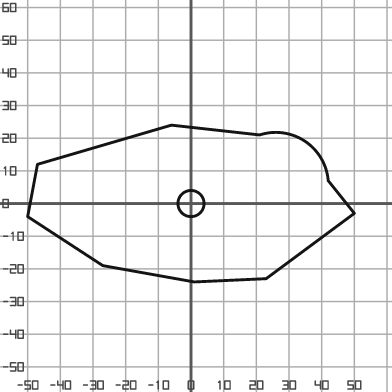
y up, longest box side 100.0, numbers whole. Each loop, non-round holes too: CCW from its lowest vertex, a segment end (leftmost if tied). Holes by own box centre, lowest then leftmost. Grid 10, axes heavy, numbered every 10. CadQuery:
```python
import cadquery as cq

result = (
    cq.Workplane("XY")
    .moveTo(1.0, -24.0)
    .lineTo(23.0, -23.0)
    .lineTo(50.0, -3.0)
    .lineTo(42.0, 7.0)
    .threePointArc((35.0, 19.0), (21.0, 21.0))
    .lineTo(-6.0, 24.0)
    .lineTo(-47.0, 12.0)
    .lineTo(-50.0, -4.0)
    .lineTo(-27.0, -19.0)
    .close()
    .moveTo(0.0, 0.0)
    .circle(4.0)
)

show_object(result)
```